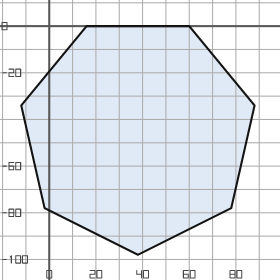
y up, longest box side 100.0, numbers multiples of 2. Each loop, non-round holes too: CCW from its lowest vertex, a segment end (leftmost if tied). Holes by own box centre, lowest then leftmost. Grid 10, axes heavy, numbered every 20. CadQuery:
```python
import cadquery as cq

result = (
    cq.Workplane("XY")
    .moveTo(38.0, -98.0)
    .lineTo(78.0, -78.0)
    .lineTo(88.0, -34.0)
    .lineTo(60.0, 0.0)
    .lineTo(16.0, 0.0)
    .lineTo(-12.0, -34.0)
    .lineTo(-2.0, -78.0)
    .close()
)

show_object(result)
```